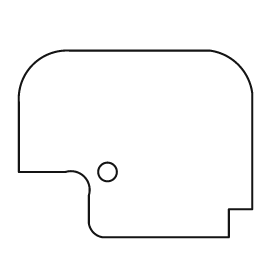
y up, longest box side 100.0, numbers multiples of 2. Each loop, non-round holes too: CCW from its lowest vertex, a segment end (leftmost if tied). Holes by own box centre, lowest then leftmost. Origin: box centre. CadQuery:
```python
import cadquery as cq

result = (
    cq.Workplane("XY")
    .moveTo(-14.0, -40.0)
    .lineTo(40.0, -40.0)
    .lineTo(40.0, -28.0)
    .lineTo(50.0, -28.0)
    .lineTo(50.0, 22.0)
    .threePointArc((44.0, 34.0), (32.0, 40.0))
    .lineTo(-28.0, 40.0)
    .threePointArc((-44.0, 34.0), (-50.0, 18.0))
    .lineTo(-50.0, -12.0)
    .lineTo(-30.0, -12.0)
    .threePointArc((-22.0, -14.0), (-20.0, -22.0))
    .lineTo(-20.0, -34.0)
    .threePointArc((-18.0, -38.0), (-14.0, -40.0))
    .close()
    .moveTo(-12.0, -12.0)
    .circle(4.0)
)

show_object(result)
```